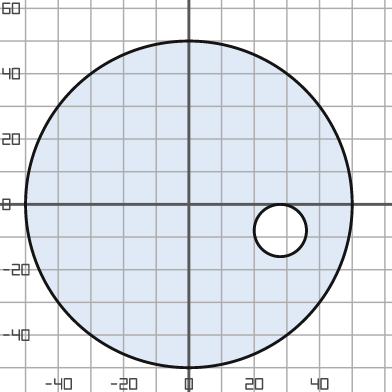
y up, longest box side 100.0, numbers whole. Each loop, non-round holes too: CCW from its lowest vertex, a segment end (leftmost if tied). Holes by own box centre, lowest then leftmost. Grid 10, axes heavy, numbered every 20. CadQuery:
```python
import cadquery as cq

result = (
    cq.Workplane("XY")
    .moveTo(0.0, 0.0)
    .circle(50.0)
    .moveTo(28.0, -8.0)
    .circle(8.0)
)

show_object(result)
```